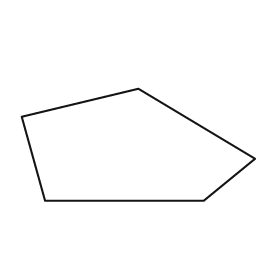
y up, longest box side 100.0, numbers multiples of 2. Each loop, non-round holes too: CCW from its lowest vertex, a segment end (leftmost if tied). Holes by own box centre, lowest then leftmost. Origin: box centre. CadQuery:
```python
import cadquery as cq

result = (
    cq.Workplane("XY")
    .moveTo(-40.0, -24.0)
    .lineTo(28.0, -24.0)
    .lineTo(50.0, -6.0)
    .lineTo(0.0, 24.0)
    .lineTo(-50.0, 12.0)
    .close()
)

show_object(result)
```